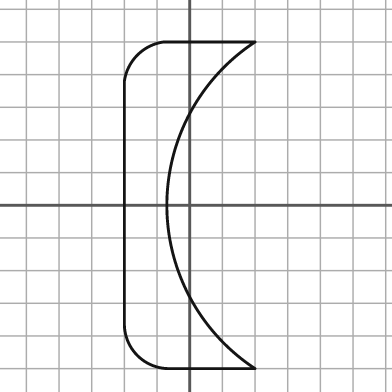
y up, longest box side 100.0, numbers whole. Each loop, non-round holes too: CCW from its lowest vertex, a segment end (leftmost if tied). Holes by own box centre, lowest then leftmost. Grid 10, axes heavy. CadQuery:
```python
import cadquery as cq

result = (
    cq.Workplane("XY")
    .moveTo(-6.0, -50.0)
    .lineTo(20.0, -50.0)
    .threePointArc((-7.0, 0.0), (20.0, 50.0))
    .lineTo(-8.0, 50.0)
    .threePointArc((-16.0, 46.0), (-20.0, 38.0))
    .lineTo(-20.0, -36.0)
    .threePointArc((-16.0, -46.0), (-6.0, -50.0))
    .close()
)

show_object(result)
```